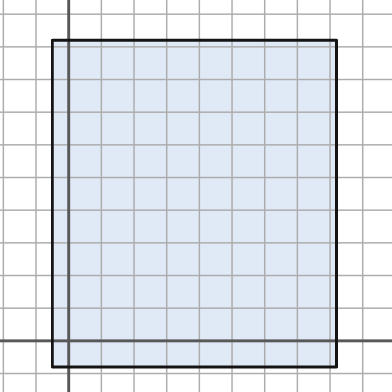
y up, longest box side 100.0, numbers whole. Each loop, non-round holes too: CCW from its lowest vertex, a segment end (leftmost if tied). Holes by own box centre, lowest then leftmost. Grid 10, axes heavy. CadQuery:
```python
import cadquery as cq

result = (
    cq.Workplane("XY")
    .moveTo(-5.0, -8.0)
    .lineTo(82.0, -8.0)
    .lineTo(82.0, 92.0)
    .lineTo(-5.0, 92.0)
    .close()
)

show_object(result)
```